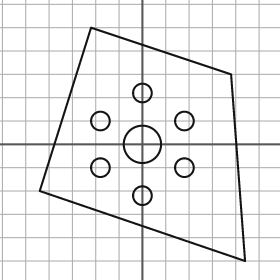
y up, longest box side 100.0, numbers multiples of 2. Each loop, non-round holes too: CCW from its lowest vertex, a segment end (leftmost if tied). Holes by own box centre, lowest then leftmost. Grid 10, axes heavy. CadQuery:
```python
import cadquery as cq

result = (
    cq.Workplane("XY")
    .moveTo(44.0, -50.0)
    .lineTo(38.0, 30.0)
    .lineTo(-22.0, 50.0)
    .lineTo(-44.0, -20.0)
    .close()
    .moveTo(0.0, -22.0)
    .circle(4.0)
    .moveTo(-18.0, -10.0)
    .circle(4.0)
    .moveTo(18.0, -10.0)
    .circle(4.0)
    .moveTo(0.0, 0.0)
    .circle(8.0)
    .moveTo(-18.0, 10.0)
    .circle(4.0)
    .moveTo(18.0, 10.0)
    .circle(4.0)
    .moveTo(0.0, 22.0)
    .circle(4.0)
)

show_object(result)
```